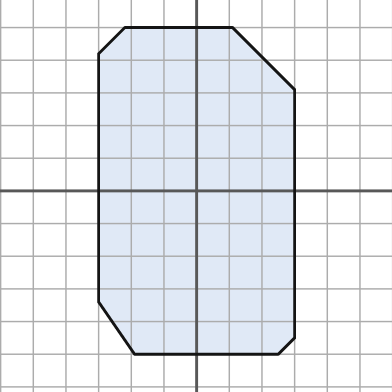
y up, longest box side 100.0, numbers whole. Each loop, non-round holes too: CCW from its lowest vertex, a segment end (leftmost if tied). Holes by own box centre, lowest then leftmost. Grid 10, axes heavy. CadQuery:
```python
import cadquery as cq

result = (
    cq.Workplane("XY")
    .moveTo(-19.0, -50.0)
    .lineTo(25.0, -50.0)
    .lineTo(30.0, -45.0)
    .lineTo(30.0, 31.0)
    .lineTo(11.0, 50.0)
    .lineTo(-22.0, 50.0)
    .lineTo(-30.0, 42.0)
    .lineTo(-30.0, -34.0)
    .close()
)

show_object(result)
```